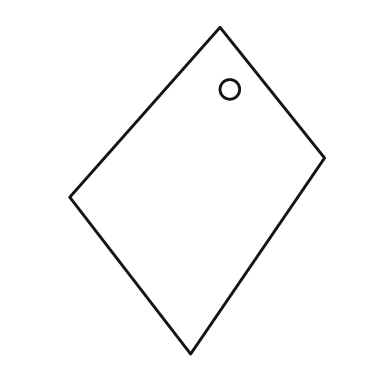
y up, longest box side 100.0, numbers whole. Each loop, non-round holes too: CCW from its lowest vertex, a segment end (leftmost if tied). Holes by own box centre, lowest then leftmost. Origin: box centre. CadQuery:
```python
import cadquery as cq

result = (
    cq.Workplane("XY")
    .moveTo(-2.0, -50.0)
    .lineTo(39.0, 10.0)
    .lineTo(7.0, 50.0)
    .lineTo(-39.0, -2.0)
    .close()
    .moveTo(10.0, 31.0)
    .circle(3.0)
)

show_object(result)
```